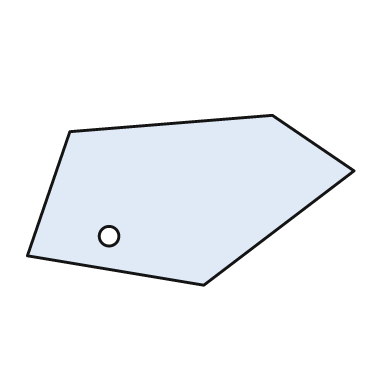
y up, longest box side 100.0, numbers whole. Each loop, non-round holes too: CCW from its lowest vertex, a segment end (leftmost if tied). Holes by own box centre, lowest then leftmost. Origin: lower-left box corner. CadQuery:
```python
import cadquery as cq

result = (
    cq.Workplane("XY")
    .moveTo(54.0, 0.0)
    .lineTo(100.0, 35.0)
    .lineTo(75.0, 52.0)
    .lineTo(13.0, 47.0)
    .lineTo(0.0, 9.0)
    .close()
    .moveTo(25.0, 15.0)
    .circle(3.0)
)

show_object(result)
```